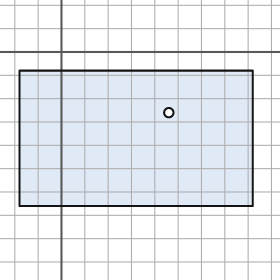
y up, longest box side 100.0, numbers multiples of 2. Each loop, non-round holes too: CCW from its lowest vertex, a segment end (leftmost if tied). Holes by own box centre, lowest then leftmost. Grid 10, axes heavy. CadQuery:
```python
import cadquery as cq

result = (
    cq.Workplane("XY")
    .moveTo(-18.0, -66.0)
    .lineTo(82.0, -66.0)
    .lineTo(82.0, -8.0)
    .lineTo(-18.0, -8.0)
    .close()
    .moveTo(46.0, -26.0)
    .circle(2.0)
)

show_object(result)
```